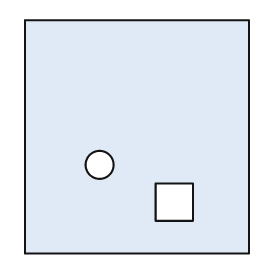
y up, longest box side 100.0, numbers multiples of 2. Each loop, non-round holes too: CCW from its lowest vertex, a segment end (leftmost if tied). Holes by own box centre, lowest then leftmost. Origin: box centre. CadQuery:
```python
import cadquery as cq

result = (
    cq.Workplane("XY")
    .moveTo(-48.0, -50.0)
    .lineTo(48.0, -50.0)
    .lineTo(48.0, 50.0)
    .lineTo(-48.0, 50.0)
    .close()
    .moveTo(8.0, -36.0)
    .lineTo(24.0, -36.0)
    .lineTo(24.0, -20.0)
    .lineTo(8.0, -20.0)
    .close()
    .moveTo(-16.0, -12.0)
    .circle(6.0)
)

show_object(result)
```